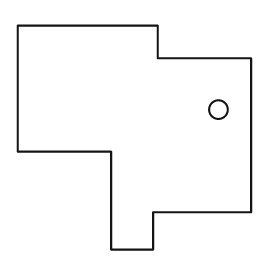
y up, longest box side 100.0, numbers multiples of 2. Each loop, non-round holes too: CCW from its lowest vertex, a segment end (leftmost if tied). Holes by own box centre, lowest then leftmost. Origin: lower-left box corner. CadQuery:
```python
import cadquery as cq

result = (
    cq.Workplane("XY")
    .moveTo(40.0, 0.0)
    .lineTo(58.0, 0.0)
    .lineTo(58.0, 16.0)
    .lineTo(100.0, 16.0)
    .lineTo(100.0, 82.0)
    .lineTo(60.0, 82.0)
    .lineTo(60.0, 96.0)
    .lineTo(0.0, 96.0)
    .lineTo(0.0, 42.0)
    .lineTo(40.0, 42.0)
    .close()
    .moveTo(86.0, 60.0)
    .circle(4.0)
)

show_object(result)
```